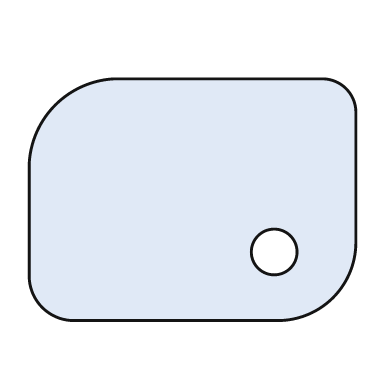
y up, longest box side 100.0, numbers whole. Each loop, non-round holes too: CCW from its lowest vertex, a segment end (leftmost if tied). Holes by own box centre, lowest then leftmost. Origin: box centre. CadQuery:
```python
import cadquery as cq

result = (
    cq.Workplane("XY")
    .moveTo(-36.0, -37.0)
    .lineTo(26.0, -37.0)
    .threePointArc((43.0, -30.0), (50.0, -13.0))
    .lineTo(50.0, 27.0)
    .threePointArc((47.0, 34.0), (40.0, 37.0))
    .lineTo(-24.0, 37.0)
    .threePointArc((-42.0, 29.0), (-50.0, 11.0))
    .lineTo(-50.0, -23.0)
    .threePointArc((-46.0, -33.0), (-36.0, -37.0))
    .close()
    .moveTo(25.0, -16.0)
    .circle(7.0)
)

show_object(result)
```